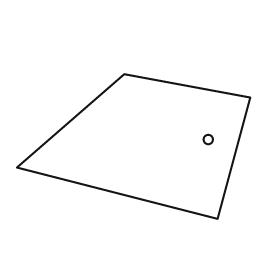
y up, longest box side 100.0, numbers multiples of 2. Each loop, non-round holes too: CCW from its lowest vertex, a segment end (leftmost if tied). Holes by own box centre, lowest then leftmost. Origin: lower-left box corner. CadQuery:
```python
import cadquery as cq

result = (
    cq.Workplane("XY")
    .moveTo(86.0, 0.0)
    .lineTo(100.0, 52.0)
    .lineTo(46.0, 62.0)
    .lineTo(0.0, 22.0)
    .close()
    .moveTo(82.0, 34.0)
    .circle(2.0)
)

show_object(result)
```